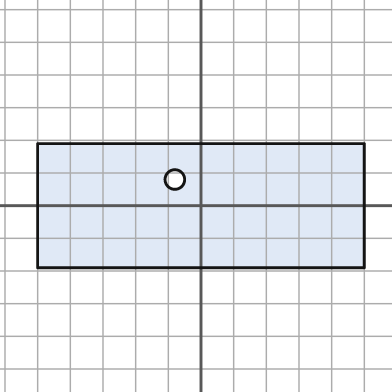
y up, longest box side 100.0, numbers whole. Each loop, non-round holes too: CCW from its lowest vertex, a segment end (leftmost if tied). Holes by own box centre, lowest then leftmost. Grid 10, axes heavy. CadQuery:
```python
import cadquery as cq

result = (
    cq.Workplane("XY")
    .moveTo(-50.0, -19.0)
    .lineTo(50.0, -19.0)
    .lineTo(50.0, 19.0)
    .lineTo(-50.0, 19.0)
    .close()
    .moveTo(-8.0, 8.0)
    .circle(3.0)
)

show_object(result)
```